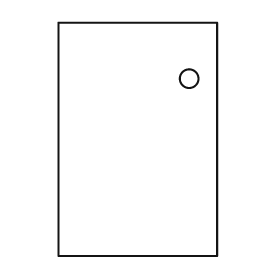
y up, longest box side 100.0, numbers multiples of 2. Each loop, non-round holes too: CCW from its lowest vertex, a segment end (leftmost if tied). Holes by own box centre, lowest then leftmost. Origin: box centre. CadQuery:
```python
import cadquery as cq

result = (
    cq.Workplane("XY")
    .moveTo(-34.0, -50.0)
    .lineTo(34.0, -50.0)
    .lineTo(34.0, 50.0)
    .lineTo(-34.0, 50.0)
    .close()
    .moveTo(22.0, 26.0)
    .circle(4.0)
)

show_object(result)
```